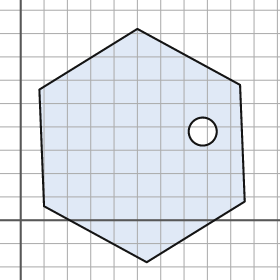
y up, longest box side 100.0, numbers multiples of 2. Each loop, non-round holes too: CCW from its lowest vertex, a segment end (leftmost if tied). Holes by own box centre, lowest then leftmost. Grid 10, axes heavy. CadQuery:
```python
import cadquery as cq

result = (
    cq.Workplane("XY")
    .moveTo(54.0, -18.0)
    .lineTo(96.0, 8.0)
    .lineTo(94.0, 58.0)
    .lineTo(50.0, 82.0)
    .lineTo(8.0, 56.0)
    .lineTo(10.0, 6.0)
    .close()
    .moveTo(78.0, 38.0)
    .circle(6.0)
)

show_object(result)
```